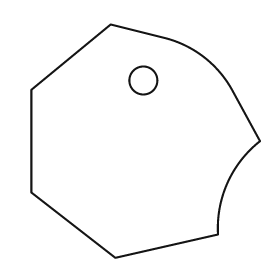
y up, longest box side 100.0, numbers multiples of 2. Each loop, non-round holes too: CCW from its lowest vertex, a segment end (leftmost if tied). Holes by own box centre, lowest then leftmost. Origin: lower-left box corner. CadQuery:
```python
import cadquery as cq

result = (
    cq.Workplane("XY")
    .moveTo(36.0, 0.0)
    .lineTo(80.0, 10.0)
    .threePointArc((84.0, 32.0), (98.0, 50.0))
    .lineTo(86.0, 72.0)
    .threePointArc((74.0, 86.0), (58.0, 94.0))
    .lineTo(34.0, 100.0)
    .lineTo(0.0, 72.0)
    .lineTo(0.0, 28.0)
    .close()
    .moveTo(48.0, 76.0)
    .circle(6.0)
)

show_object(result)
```